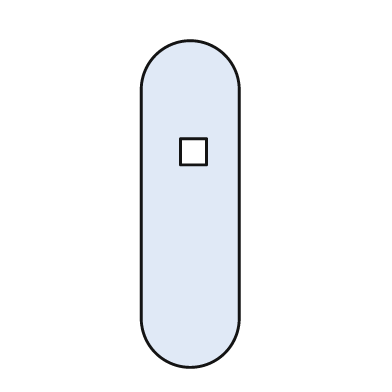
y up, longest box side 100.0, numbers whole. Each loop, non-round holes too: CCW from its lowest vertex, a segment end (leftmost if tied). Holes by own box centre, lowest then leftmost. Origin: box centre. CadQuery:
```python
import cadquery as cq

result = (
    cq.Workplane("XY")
    .moveTo(-15.0, -35.0)
    .threePointArc((0.0, -50.0), (15.0, -35.0))
    .lineTo(15.0, 35.0)
    .threePointArc((0.0, 50.0), (-15.0, 35.0))
    .close()
    .moveTo(-3.0, 12.0)
    .lineTo(5.0, 12.0)
    .lineTo(5.0, 20.0)
    .lineTo(-3.0, 20.0)
    .close()
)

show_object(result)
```